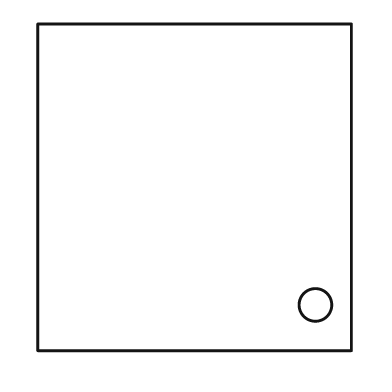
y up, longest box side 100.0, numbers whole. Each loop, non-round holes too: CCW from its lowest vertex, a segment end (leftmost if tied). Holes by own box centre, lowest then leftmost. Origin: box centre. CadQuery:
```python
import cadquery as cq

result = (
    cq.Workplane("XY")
    .moveTo(-48.0, -50.0)
    .lineTo(48.0, -50.0)
    .lineTo(48.0, 50.0)
    .lineTo(-48.0, 50.0)
    .close()
    .moveTo(37.0, -36.0)
    .circle(5.0)
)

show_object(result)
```